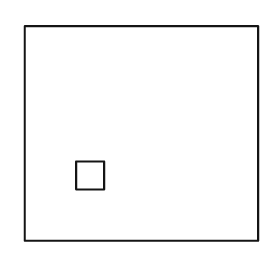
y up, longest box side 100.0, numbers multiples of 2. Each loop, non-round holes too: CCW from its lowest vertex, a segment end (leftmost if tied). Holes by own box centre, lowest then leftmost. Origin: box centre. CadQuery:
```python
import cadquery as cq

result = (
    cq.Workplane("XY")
    .moveTo(-50.0, -46.0)
    .lineTo(50.0, -46.0)
    .lineTo(50.0, 46.0)
    .lineTo(-50.0, 46.0)
    .close()
    .moveTo(-28.0, -24.0)
    .lineTo(-16.0, -24.0)
    .lineTo(-16.0, -12.0)
    .lineTo(-28.0, -12.0)
    .close()
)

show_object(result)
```